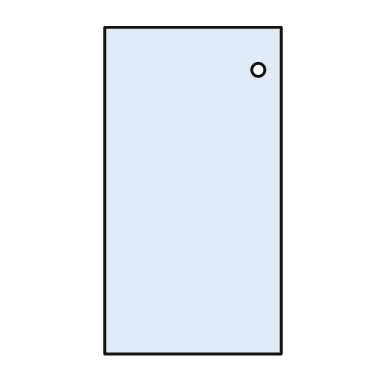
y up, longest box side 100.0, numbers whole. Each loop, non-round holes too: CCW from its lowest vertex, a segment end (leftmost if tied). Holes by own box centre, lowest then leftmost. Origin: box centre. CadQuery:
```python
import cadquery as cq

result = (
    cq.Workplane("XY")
    .moveTo(-27.0, -50.0)
    .lineTo(27.0, -50.0)
    .lineTo(27.0, 50.0)
    .lineTo(-27.0, 50.0)
    .close()
    .moveTo(20.0, 37.0)
    .circle(2.0)
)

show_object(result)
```